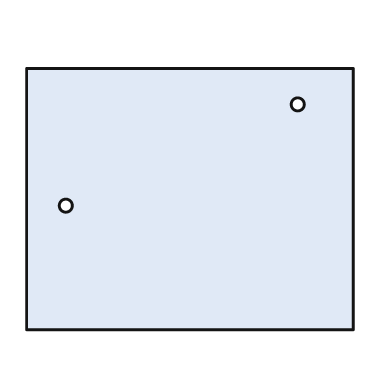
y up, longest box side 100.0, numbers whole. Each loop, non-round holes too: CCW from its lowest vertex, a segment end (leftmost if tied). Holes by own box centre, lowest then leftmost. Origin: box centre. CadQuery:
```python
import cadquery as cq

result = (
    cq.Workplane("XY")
    .moveTo(-50.0, -40.0)
    .lineTo(50.0, -40.0)
    .lineTo(50.0, 40.0)
    .lineTo(-50.0, 40.0)
    .close()
    .moveTo(-38.0, -2.0)
    .circle(2.0)
    .moveTo(33.0, 29.0)
    .circle(2.0)
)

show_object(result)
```